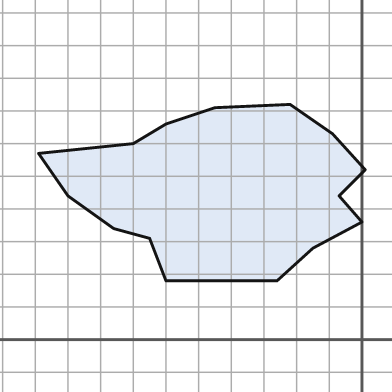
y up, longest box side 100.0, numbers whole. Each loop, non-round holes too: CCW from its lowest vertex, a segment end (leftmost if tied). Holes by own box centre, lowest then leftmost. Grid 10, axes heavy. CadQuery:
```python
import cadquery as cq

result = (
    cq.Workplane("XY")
    .moveTo(-60.0, 18.0)
    .lineTo(-26.0, 18.0)
    .lineTo(-15.0, 28.0)
    .lineTo(0.0, 36.0)
    .lineTo(-7.0, 44.0)
    .lineTo(1.0, 52.0)
    .lineTo(-9.0, 63.0)
    .lineTo(-22.0, 72.0)
    .lineTo(-45.0, 71.0)
    .lineTo(-60.0, 66.0)
    .lineTo(-70.0, 60.0)
    .lineTo(-99.0, 57.0)
    .lineTo(-90.0, 44.0)
    .lineTo(-76.0, 34.0)
    .lineTo(-65.0, 31.0)
    .close()
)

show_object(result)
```